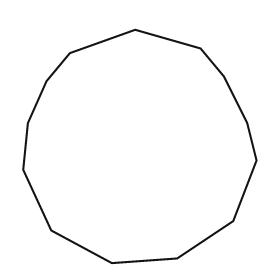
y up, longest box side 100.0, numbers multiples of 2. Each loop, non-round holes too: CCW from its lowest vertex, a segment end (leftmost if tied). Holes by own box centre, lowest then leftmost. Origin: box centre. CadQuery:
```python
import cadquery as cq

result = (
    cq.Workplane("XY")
    .moveTo(-12.0, -50.0)
    .lineTo(16.0, -48.0)
    .lineTo(40.0, -32.0)
    .lineTo(50.0, -6.0)
    .lineTo(46.0, 10.0)
    .lineTo(36.0, 30.0)
    .lineTo(26.0, 42.0)
    .lineTo(-2.0, 50.0)
    .lineTo(-30.0, 40.0)
    .lineTo(-40.0, 28.0)
    .lineTo(-48.0, 10.0)
    .lineTo(-50.0, -10.0)
    .lineTo(-38.0, -36.0)
    .close()
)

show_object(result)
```